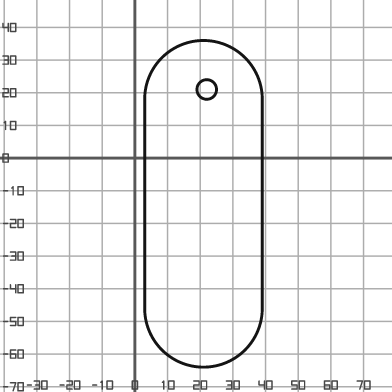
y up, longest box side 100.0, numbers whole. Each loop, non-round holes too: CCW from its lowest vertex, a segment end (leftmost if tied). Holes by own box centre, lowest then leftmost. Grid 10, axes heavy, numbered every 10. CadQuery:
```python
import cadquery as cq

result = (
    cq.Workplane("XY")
    .moveTo(3.0, -46.0)
    .threePointArc((21.0, -64.0), (39.0, -46.0))
    .lineTo(39.0, 18.0)
    .threePointArc((21.0, 36.0), (3.0, 18.0))
    .close()
    .moveTo(22.0, 21.0)
    .circle(3.0)
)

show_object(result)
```